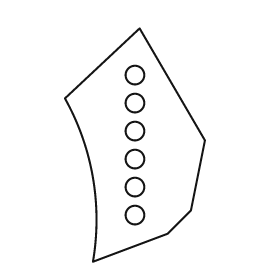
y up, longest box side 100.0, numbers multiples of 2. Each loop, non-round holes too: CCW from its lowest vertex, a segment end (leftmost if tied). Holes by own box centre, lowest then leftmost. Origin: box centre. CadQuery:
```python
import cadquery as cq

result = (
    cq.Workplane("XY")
    .moveTo(-18.0, -50.0)
    .lineTo(14.0, -38.0)
    .lineTo(24.0, -28.0)
    .lineTo(30.0, 2.0)
    .lineTo(2.0, 50.0)
    .lineTo(-30.0, 20.0)
    .threePointArc((-18.0, -14.0), (-18.0, -50.0))
    .close()
    .moveTo(0.0, -30.0)
    .circle(4.0)
    .moveTo(0.0, -18.0)
    .circle(4.0)
    .moveTo(0.0, -6.0)
    .circle(4.0)
    .moveTo(0.0, 6.0)
    .circle(4.0)
    .moveTo(0.0, 18.0)
    .circle(4.0)
    .moveTo(0.0, 30.0)
    .circle(4.0)
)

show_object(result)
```